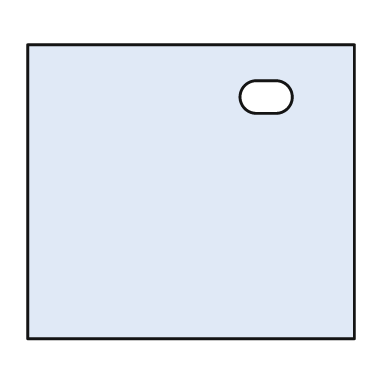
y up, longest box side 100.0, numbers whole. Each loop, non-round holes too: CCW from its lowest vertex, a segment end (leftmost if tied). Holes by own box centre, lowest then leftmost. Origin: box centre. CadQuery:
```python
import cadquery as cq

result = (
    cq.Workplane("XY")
    .moveTo(-50.0, -45.0)
    .lineTo(50.0, -45.0)
    .lineTo(50.0, 45.0)
    .lineTo(-50.0, 45.0)
    .close()
    .moveTo(20.0, 24.0)
    .lineTo(26.0, 24.0)
    .threePointArc((31.0, 29.0), (26.0, 34.0))
    .lineTo(20.0, 34.0)
    .threePointArc((15.0, 29.0), (20.0, 24.0))
    .close()
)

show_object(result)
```